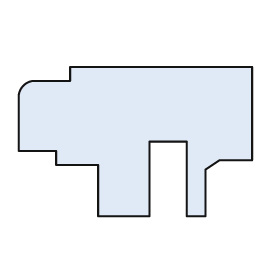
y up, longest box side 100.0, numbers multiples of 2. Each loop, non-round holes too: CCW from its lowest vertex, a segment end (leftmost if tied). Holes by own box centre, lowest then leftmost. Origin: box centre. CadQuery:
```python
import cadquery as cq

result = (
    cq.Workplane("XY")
    .moveTo(-16.0, -32.0)
    .lineTo(6.0, -32.0)
    .lineTo(6.0, 0.0)
    .lineTo(22.0, 0.0)
    .lineTo(22.0, -32.0)
    .lineTo(30.0, -32.0)
    .lineTo(30.0, -12.0)
    .lineTo(36.0, -8.0)
    .lineTo(50.0, -8.0)
    .lineTo(50.0, 32.0)
    .lineTo(-28.0, 32.0)
    .lineTo(-28.0, 26.0)
    .lineTo(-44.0, 26.0)
    .threePointArc((-48.0, 24.0), (-50.0, 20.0))
    .lineTo(-50.0, -4.0)
    .lineTo(-34.0, -4.0)
    .lineTo(-34.0, -10.0)
    .lineTo(-16.0, -10.0)
    .close()
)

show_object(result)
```